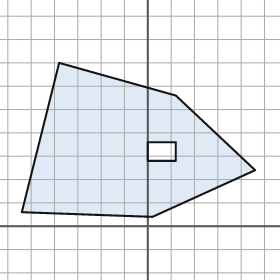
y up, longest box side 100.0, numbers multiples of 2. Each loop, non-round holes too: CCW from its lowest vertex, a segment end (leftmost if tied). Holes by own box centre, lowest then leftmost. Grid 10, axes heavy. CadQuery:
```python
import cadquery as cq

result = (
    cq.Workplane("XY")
    .moveTo(2.0, 4.0)
    .lineTo(46.0, 24.0)
    .lineTo(12.0, 56.0)
    .lineTo(-38.0, 70.0)
    .lineTo(-54.0, 6.0)
    .close()
    .moveTo(0.0, 28.0)
    .lineTo(12.0, 28.0)
    .lineTo(12.0, 36.0)
    .lineTo(0.0, 36.0)
    .close()
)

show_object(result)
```